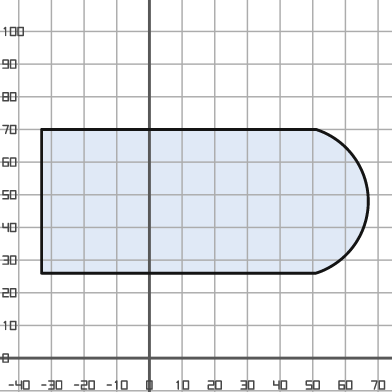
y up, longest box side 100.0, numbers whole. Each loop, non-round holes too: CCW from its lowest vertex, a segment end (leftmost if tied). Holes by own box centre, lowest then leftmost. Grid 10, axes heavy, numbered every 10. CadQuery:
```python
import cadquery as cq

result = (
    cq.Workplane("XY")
    .moveTo(-33.0, 26.0)
    .lineTo(51.0, 26.0)
    .threePointArc((67.0, 48.0), (51.0, 70.0))
    .lineTo(-33.0, 70.0)
    .close()
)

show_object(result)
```